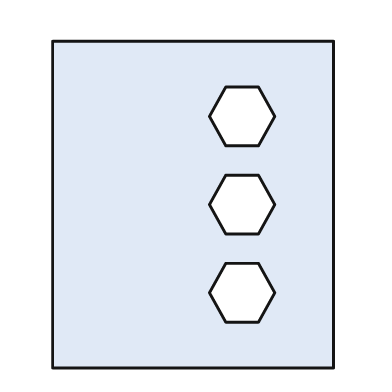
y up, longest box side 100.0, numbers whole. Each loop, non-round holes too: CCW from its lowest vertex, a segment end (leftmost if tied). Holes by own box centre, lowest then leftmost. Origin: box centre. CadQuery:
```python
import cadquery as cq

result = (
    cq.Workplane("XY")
    .moveTo(-43.0, -50.0)
    .lineTo(43.0, -50.0)
    .lineTo(43.0, 50.0)
    .lineTo(-43.0, 50.0)
    .close()
    .moveTo(10.0, -36.0)
    .lineTo(20.0, -36.0)
    .lineTo(25.0, -27.0)
    .lineTo(20.0, -18.0)
    .lineTo(10.0, -18.0)
    .lineTo(5.0, -27.0)
    .close()
    .moveTo(10.0, -9.0)
    .lineTo(20.0, -9.0)
    .lineTo(25.0, 0.0)
    .lineTo(20.0, 9.0)
    .lineTo(10.0, 9.0)
    .lineTo(5.0, 0.0)
    .close()
    .moveTo(10.0, 18.0)
    .lineTo(20.0, 18.0)
    .lineTo(25.0, 27.0)
    .lineTo(20.0, 36.0)
    .lineTo(10.0, 36.0)
    .lineTo(5.0, 27.0)
    .close()
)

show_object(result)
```